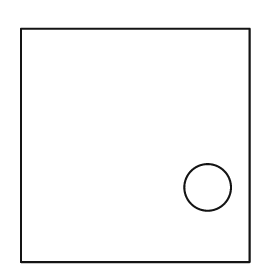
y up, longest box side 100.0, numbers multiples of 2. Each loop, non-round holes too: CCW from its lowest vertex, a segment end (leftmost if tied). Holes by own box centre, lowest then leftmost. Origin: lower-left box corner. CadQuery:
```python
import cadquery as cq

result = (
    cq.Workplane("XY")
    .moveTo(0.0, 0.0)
    .lineTo(98.0, 0.0)
    .lineTo(98.0, 100.0)
    .lineTo(0.0, 100.0)
    .close()
    .moveTo(80.0, 32.0)
    .circle(10.0)
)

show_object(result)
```